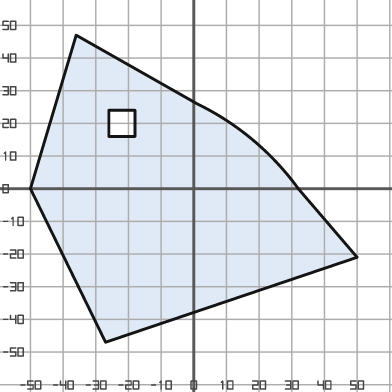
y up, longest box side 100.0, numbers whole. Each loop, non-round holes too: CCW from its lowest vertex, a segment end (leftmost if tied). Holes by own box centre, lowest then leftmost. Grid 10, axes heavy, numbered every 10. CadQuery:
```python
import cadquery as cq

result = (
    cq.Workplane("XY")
    .moveTo(-27.0, -47.0)
    .lineTo(50.0, -21.0)
    .lineTo(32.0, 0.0)
    .threePointArc((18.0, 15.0), (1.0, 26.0))
    .lineTo(-36.0, 47.0)
    .lineTo(-50.0, 0.0)
    .close()
    .moveTo(-26.0, 16.0)
    .lineTo(-18.0, 16.0)
    .lineTo(-18.0, 24.0)
    .lineTo(-26.0, 24.0)
    .close()
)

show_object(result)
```